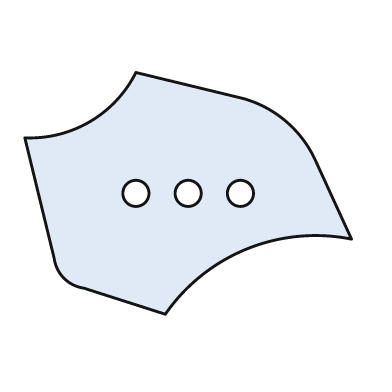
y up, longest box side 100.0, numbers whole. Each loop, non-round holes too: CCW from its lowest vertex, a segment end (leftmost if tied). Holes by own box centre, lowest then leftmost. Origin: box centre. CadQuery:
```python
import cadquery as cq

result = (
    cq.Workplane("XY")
    .moveTo(-7.0, -37.0)
    .threePointArc((18.0, -17.0), (50.0, -14.0))
    .lineTo(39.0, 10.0)
    .threePointArc((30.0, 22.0), (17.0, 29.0))
    .lineTo(-16.0, 37.0)
    .threePointArc((-30.0, 22.0), (-50.0, 17.0))
    .lineTo(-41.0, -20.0)
    .threePointArc((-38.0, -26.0), (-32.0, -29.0))
    .close()
    .moveTo(-16.0, 0.0)
    .circle(4.0)
    .moveTo(0.0, 0.0)
    .circle(4.0)
    .moveTo(16.0, 0.0)
    .circle(4.0)
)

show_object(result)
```